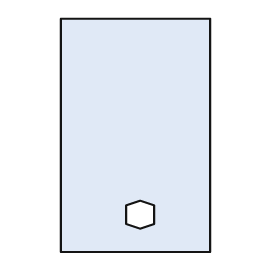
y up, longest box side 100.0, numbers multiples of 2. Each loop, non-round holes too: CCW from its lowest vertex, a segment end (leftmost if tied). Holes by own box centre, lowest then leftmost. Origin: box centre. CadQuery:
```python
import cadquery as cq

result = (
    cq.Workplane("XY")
    .moveTo(-32.0, -50.0)
    .lineTo(32.0, -50.0)
    .lineTo(32.0, 50.0)
    .lineTo(-32.0, 50.0)
    .close()
    .moveTo(2.0, -40.0)
    .lineTo(8.0, -38.0)
    .lineTo(8.0, -30.0)
    .lineTo(2.0, -28.0)
    .lineTo(-4.0, -30.0)
    .lineTo(-4.0, -38.0)
    .close()
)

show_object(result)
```